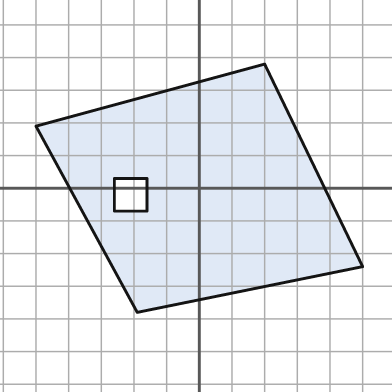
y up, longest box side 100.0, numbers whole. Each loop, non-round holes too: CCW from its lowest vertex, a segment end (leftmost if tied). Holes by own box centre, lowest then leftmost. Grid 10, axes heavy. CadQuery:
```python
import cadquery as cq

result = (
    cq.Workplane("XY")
    .moveTo(-19.0, -38.0)
    .lineTo(50.0, -24.0)
    .lineTo(20.0, 38.0)
    .lineTo(-50.0, 19.0)
    .close()
    .moveTo(-26.0, -7.0)
    .lineTo(-16.0, -7.0)
    .lineTo(-16.0, 3.0)
    .lineTo(-26.0, 3.0)
    .close()
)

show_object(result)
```